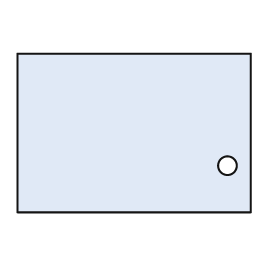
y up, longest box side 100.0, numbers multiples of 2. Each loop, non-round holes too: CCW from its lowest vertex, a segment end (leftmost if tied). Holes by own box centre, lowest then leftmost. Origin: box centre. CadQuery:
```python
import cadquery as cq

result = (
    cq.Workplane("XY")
    .moveTo(-50.0, -34.0)
    .lineTo(50.0, -34.0)
    .lineTo(50.0, 34.0)
    .lineTo(-50.0, 34.0)
    .close()
    .moveTo(40.0, -14.0)
    .circle(4.0)
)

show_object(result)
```